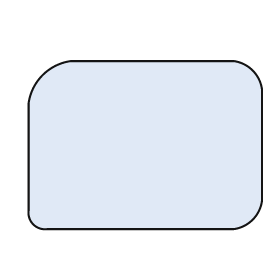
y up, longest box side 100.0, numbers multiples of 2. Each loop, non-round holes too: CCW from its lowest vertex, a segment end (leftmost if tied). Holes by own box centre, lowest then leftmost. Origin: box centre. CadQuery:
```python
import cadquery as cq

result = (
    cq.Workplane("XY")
    .moveTo(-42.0, -36.0)
    .lineTo(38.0, -36.0)
    .threePointArc((46.0, -32.0), (50.0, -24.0))
    .lineTo(50.0, 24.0)
    .threePointArc((46.0, 32.0), (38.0, 36.0))
    .lineTo(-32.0, 36.0)
    .threePointArc((-44.0, 30.0), (-50.0, 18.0))
    .lineTo(-50.0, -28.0)
    .threePointArc((-48.0, -34.0), (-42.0, -36.0))
    .close()
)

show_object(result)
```